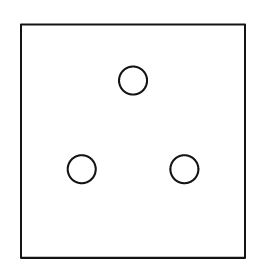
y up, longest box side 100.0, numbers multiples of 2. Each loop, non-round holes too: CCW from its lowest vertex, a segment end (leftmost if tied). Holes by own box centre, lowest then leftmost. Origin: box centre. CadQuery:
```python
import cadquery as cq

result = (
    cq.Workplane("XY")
    .moveTo(-48.0, -50.0)
    .lineTo(48.0, -50.0)
    .lineTo(48.0, 50.0)
    .lineTo(-48.0, 50.0)
    .close()
    .moveTo(-22.0, -12.0)
    .circle(6.0)
    .moveTo(22.0, -12.0)
    .circle(6.0)
    .moveTo(0.0, 26.0)
    .circle(6.0)
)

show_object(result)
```